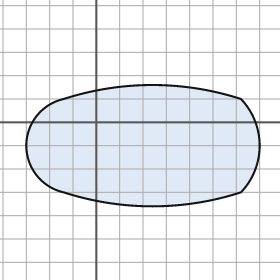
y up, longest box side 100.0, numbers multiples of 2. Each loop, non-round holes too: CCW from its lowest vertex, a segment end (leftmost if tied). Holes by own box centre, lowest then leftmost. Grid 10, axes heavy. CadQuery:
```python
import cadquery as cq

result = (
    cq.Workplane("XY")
    .moveTo(-14.0, -30.0)
    .threePointArc((24.0, -36.0), (62.0, -30.0))
    .threePointArc((70.0, -10.0), (62.0, 10.0))
    .threePointArc((24.0, 16.0), (-14.0, 10.0))
    .threePointArc((-30.0, -10.0), (-14.0, -30.0))
    .close()
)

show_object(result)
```